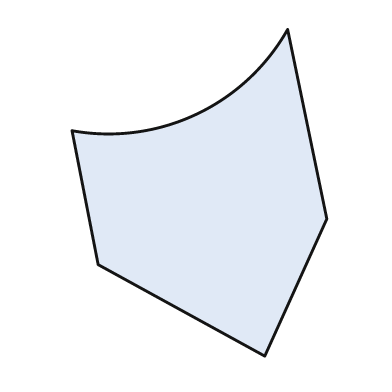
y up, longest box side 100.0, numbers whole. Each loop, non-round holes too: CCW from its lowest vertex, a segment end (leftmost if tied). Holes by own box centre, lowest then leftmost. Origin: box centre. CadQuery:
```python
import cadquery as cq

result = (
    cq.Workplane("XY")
    .moveTo(20.0, -50.0)
    .lineTo(39.0, -8.0)
    .lineTo(27.0, 50.0)
    .threePointArc((-1.0, 24.0), (-39.0, 19.0))
    .lineTo(-31.0, -22.0)
    .close()
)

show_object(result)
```